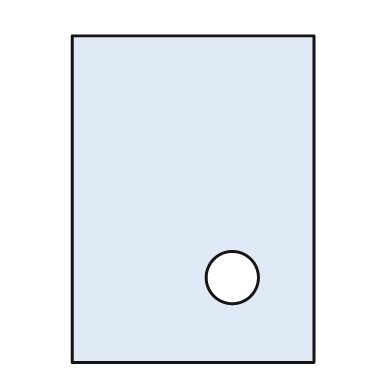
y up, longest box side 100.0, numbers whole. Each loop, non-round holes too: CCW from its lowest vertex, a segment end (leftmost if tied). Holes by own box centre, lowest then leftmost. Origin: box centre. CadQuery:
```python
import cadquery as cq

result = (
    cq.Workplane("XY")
    .moveTo(-37.0, -50.0)
    .lineTo(37.0, -50.0)
    .lineTo(37.0, 50.0)
    .lineTo(-37.0, 50.0)
    .close()
    .moveTo(12.0, -24.0)
    .circle(8.0)
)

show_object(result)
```